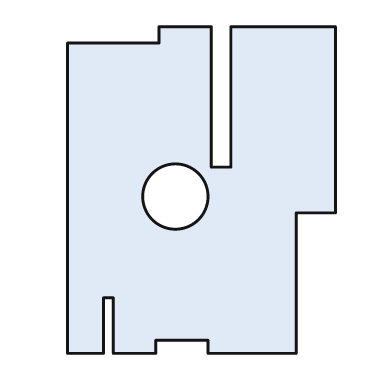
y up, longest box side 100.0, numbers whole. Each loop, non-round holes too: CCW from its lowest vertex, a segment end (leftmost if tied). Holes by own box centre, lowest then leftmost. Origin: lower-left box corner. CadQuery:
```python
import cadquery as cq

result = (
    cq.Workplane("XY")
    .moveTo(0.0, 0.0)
    .lineTo(11.0, 0.0)
    .lineTo(11.0, 17.0)
    .lineTo(14.0, 17.0)
    .lineTo(14.0, 0.0)
    .lineTo(27.0, 0.0)
    .lineTo(27.0, 4.0)
    .lineTo(43.0, 4.0)
    .lineTo(43.0, 0.0)
    .lineTo(70.0, 0.0)
    .lineTo(70.0, 43.0)
    .lineTo(82.0, 43.0)
    .lineTo(82.0, 100.0)
    .lineTo(50.0, 100.0)
    .lineTo(50.0, 57.0)
    .lineTo(44.0, 57.0)
    .lineTo(44.0, 100.0)
    .lineTo(28.0, 100.0)
    .lineTo(28.0, 95.0)
    .lineTo(0.0, 95.0)
    .close()
    .moveTo(33.0, 48.0)
    .circle(10.0)
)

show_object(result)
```